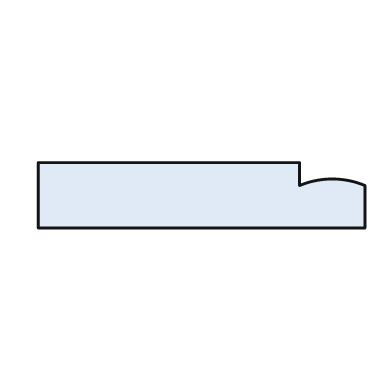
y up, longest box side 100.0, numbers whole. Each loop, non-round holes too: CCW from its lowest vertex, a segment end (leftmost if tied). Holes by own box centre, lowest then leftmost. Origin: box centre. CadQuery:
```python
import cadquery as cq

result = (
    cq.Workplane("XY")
    .moveTo(-50.0, -10.0)
    .lineTo(50.0, -10.0)
    .lineTo(50.0, 3.0)
    .threePointArc((40.0, 5.0), (30.0, 3.0))
    .lineTo(30.0, 10.0)
    .lineTo(-50.0, 10.0)
    .close()
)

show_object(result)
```